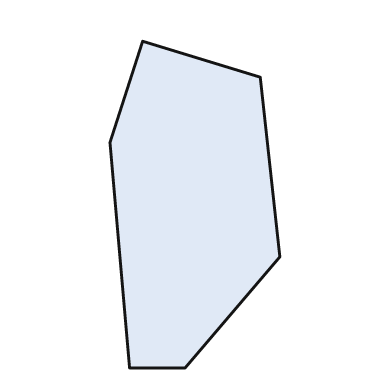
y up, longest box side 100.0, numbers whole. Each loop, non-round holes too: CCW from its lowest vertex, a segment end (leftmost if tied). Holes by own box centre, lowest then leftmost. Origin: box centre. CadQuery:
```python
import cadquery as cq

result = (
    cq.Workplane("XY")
    .moveTo(-20.0, -50.0)
    .lineTo(-3.0, -50.0)
    .lineTo(26.0, -16.0)
    .lineTo(20.0, 39.0)
    .lineTo(-16.0, 50.0)
    .lineTo(-26.0, 19.0)
    .close()
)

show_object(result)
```